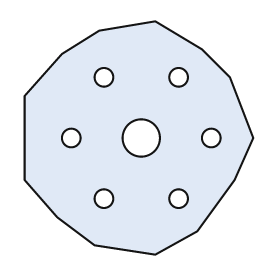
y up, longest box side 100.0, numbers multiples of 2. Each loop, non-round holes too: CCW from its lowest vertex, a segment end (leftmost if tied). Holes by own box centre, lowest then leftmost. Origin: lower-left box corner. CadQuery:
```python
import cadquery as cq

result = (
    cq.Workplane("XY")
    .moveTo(56.0, 0.0)
    .lineTo(74.0, 10.0)
    .lineTo(90.0, 32.0)
    .lineTo(98.0, 50.0)
    .lineTo(88.0, 76.0)
    .lineTo(76.0, 88.0)
    .lineTo(56.0, 100.0)
    .lineTo(32.0, 96.0)
    .lineTo(16.0, 86.0)
    .lineTo(0.0, 68.0)
    .lineTo(0.0, 32.0)
    .lineTo(14.0, 16.0)
    .lineTo(30.0, 4.0)
    .close()
    .moveTo(34.0, 24.0)
    .circle(4.0)
    .moveTo(66.0, 24.0)
    .circle(4.0)
    .moveTo(20.0, 50.0)
    .circle(4.0)
    .moveTo(50.0, 50.0)
    .circle(8.0)
    .moveTo(80.0, 50.0)
    .circle(4.0)
    .moveTo(34.0, 76.0)
    .circle(4.0)
    .moveTo(66.0, 76.0)
    .circle(4.0)
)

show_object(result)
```